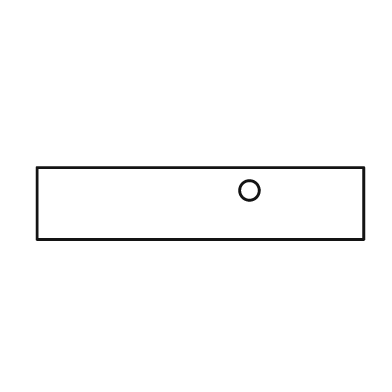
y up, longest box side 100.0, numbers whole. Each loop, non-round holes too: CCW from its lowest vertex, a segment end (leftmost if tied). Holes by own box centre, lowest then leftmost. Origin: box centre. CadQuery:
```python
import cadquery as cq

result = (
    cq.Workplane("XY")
    .moveTo(-50.0, -11.0)
    .lineTo(50.0, -11.0)
    .lineTo(50.0, 11.0)
    .lineTo(-50.0, 11.0)
    .close()
    .moveTo(15.0, 4.0)
    .circle(3.0)
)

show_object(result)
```